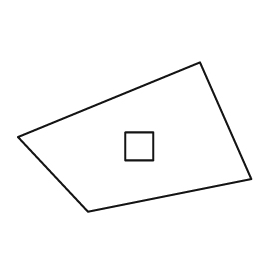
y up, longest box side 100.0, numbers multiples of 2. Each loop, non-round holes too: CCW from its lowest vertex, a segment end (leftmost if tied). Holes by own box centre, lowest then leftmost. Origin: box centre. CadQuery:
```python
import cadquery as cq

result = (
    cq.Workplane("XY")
    .moveTo(-20.0, -32.0)
    .lineTo(50.0, -18.0)
    .lineTo(28.0, 32.0)
    .lineTo(-50.0, 0.0)
    .close()
    .moveTo(-4.0, -10.0)
    .lineTo(8.0, -10.0)
    .lineTo(8.0, 2.0)
    .lineTo(-4.0, 2.0)
    .close()
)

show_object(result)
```